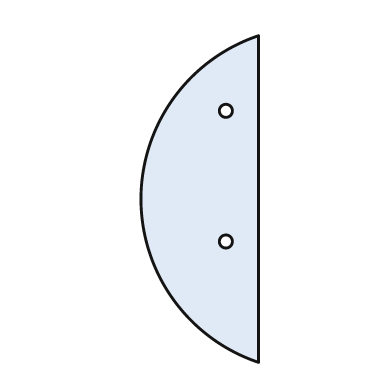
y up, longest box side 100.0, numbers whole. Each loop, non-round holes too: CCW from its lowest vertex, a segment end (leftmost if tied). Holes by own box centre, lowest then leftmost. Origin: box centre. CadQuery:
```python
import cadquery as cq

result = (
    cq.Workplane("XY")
    .moveTo(18.0, -50.0)
    .lineTo(18.0, 50.0)
    .threePointArc((-18.0, 0.0), (18.0, -50.0))
    .close()
    .moveTo(8.0, -13.0)
    .circle(2.0)
    .moveTo(8.0, 27.0)
    .circle(2.0)
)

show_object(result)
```